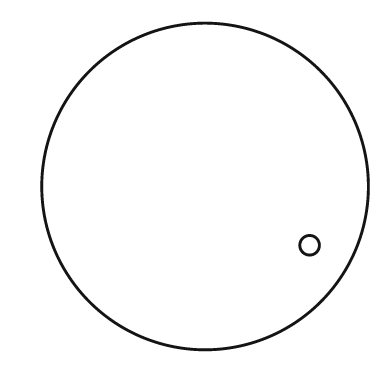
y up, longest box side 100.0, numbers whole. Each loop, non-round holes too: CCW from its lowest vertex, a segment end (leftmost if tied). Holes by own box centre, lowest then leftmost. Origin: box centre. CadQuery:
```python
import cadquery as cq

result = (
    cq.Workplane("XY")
    .moveTo(0.0, 0.0)
    .circle(50.0)
    .moveTo(32.0, -18.0)
    .circle(3.0)
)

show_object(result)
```